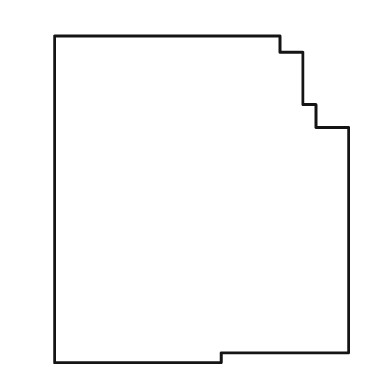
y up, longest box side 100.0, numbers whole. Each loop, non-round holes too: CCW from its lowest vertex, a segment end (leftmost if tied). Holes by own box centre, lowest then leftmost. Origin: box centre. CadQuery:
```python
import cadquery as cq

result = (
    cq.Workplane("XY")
    .moveTo(-45.0, -50.0)
    .lineTo(6.0, -50.0)
    .lineTo(6.0, -47.0)
    .lineTo(45.0, -47.0)
    .lineTo(45.0, 22.0)
    .lineTo(35.0, 22.0)
    .lineTo(35.0, 29.0)
    .lineTo(31.0, 29.0)
    .lineTo(31.0, 45.0)
    .lineTo(24.0, 45.0)
    .lineTo(24.0, 50.0)
    .lineTo(-45.0, 50.0)
    .close()
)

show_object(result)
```